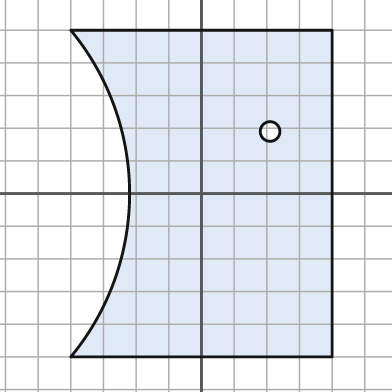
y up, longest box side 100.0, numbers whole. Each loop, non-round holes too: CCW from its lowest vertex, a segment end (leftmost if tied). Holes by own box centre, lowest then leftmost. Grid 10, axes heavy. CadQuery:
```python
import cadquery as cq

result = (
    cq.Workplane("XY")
    .moveTo(-40.0, -50.0)
    .lineTo(40.0, -50.0)
    .lineTo(40.0, 50.0)
    .lineTo(-40.0, 50.0)
    .threePointArc((-22.0, 0.0), (-40.0, -50.0))
    .close()
    .moveTo(21.0, 19.0)
    .circle(3.0)
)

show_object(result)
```